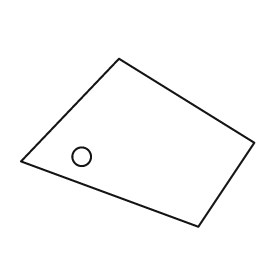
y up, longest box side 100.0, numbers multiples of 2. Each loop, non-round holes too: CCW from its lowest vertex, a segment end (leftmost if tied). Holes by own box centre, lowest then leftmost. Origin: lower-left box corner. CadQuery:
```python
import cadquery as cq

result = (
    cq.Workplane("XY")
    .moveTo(76.0, 0.0)
    .lineTo(100.0, 36.0)
    .lineTo(42.0, 72.0)
    .lineTo(0.0, 28.0)
    .close()
    .moveTo(26.0, 30.0)
    .circle(4.0)
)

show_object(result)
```